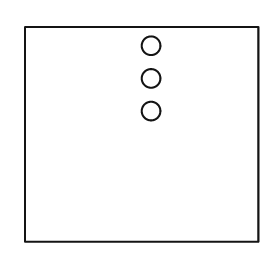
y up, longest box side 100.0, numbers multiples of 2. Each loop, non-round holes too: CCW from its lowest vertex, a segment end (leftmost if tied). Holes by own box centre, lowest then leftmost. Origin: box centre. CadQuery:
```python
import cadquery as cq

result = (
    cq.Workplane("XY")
    .moveTo(-50.0, -46.0)
    .lineTo(50.0, -46.0)
    .lineTo(50.0, 46.0)
    .lineTo(-50.0, 46.0)
    .close()
    .moveTo(4.0, 10.0)
    .circle(4.0)
    .moveTo(4.0, 24.0)
    .circle(4.0)
    .moveTo(4.0, 38.0)
    .circle(4.0)
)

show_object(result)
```